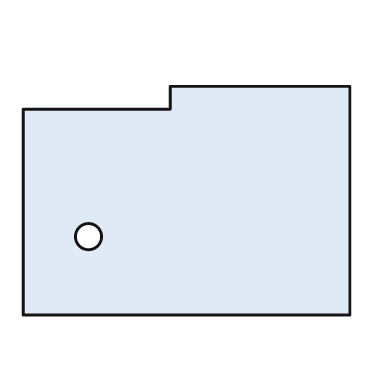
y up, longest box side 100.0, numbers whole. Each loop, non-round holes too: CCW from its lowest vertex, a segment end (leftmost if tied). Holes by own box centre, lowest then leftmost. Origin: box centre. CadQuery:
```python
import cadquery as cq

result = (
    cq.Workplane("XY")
    .moveTo(-50.0, -35.0)
    .lineTo(50.0, -35.0)
    .lineTo(50.0, 35.0)
    .lineTo(-5.0, 35.0)
    .lineTo(-5.0, 28.0)
    .lineTo(-50.0, 28.0)
    .close()
    .moveTo(-30.0, -11.0)
    .circle(4.0)
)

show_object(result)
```